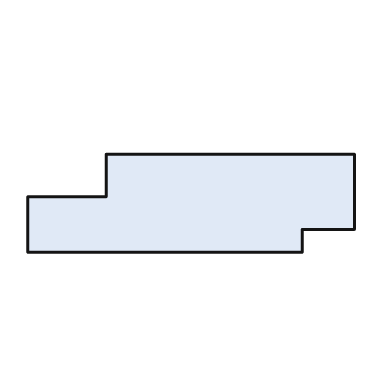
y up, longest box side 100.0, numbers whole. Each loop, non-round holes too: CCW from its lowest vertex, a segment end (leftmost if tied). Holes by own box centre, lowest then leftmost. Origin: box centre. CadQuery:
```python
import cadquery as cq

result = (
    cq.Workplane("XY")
    .moveTo(-50.0, -15.0)
    .lineTo(34.0, -15.0)
    .lineTo(34.0, -8.0)
    .lineTo(50.0, -8.0)
    .lineTo(50.0, 15.0)
    .lineTo(-26.0, 15.0)
    .lineTo(-26.0, 2.0)
    .lineTo(-50.0, 2.0)
    .close()
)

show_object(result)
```